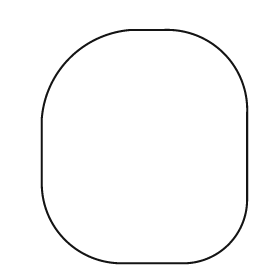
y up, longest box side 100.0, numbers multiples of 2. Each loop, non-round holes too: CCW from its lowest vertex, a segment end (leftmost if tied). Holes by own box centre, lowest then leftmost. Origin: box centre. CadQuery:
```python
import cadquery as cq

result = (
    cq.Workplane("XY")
    .moveTo(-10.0, -50.0)
    .lineTo(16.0, -50.0)
    .threePointArc((36.0, -42.0), (44.0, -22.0))
    .lineTo(44.0, 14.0)
    .threePointArc((34.0, 40.0), (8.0, 50.0))
    .lineTo(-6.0, 50.0)
    .threePointArc((-32.0, 38.0), (-44.0, 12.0))
    .lineTo(-44.0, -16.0)
    .threePointArc((-34.0, -40.0), (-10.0, -50.0))
    .close()
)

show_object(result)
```